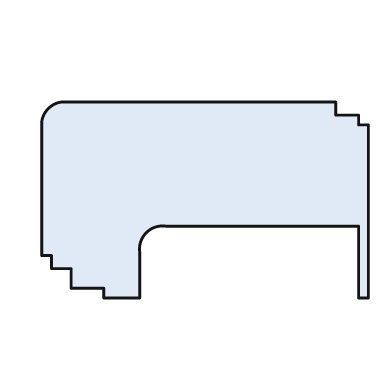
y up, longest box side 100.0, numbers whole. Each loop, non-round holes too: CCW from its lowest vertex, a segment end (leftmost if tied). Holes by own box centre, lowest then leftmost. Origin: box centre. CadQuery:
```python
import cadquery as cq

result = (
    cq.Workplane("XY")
    .moveTo(-31.0, -30.0)
    .lineTo(-20.0, -30.0)
    .lineTo(-20.0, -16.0)
    .threePointArc((-18.0, -10.0), (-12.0, -8.0))
    .lineTo(47.0, -8.0)
    .lineTo(47.0, -30.0)
    .lineTo(50.0, -30.0)
    .lineTo(50.0, 23.0)
    .lineTo(47.0, 23.0)
    .lineTo(47.0, 26.0)
    .lineTo(40.0, 26.0)
    .lineTo(40.0, 30.0)
    .lineTo(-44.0, 30.0)
    .threePointArc((-48.0, 28.0), (-50.0, 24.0))
    .lineTo(-50.0, -17.0)
    .lineTo(-47.0, -17.0)
    .lineTo(-47.0, -21.0)
    .lineTo(-41.0, -21.0)
    .lineTo(-41.0, -27.0)
    .lineTo(-31.0, -27.0)
    .close()
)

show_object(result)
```